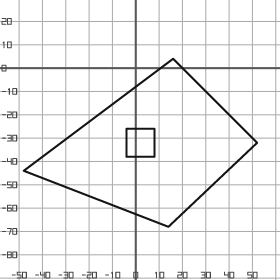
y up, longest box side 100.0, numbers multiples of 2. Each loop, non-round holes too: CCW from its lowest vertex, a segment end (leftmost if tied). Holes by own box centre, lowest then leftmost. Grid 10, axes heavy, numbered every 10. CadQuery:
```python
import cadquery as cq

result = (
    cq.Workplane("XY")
    .moveTo(14.0, -68.0)
    .lineTo(52.0, -32.0)
    .lineTo(16.0, 4.0)
    .lineTo(-48.0, -44.0)
    .close()
    .moveTo(-4.0, -38.0)
    .lineTo(8.0, -38.0)
    .lineTo(8.0, -26.0)
    .lineTo(-4.0, -26.0)
    .close()
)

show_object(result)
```